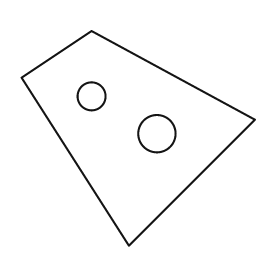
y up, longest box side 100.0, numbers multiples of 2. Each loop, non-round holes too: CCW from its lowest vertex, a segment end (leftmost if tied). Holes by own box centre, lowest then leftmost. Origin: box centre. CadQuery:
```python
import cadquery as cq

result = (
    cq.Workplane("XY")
    .moveTo(-4.0, -46.0)
    .lineTo(50.0, 8.0)
    .lineTo(-20.0, 46.0)
    .lineTo(-50.0, 26.0)
    .close()
    .moveTo(8.0, 2.0)
    .circle(8.0)
    .moveTo(-20.0, 18.0)
    .circle(6.0)
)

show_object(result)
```